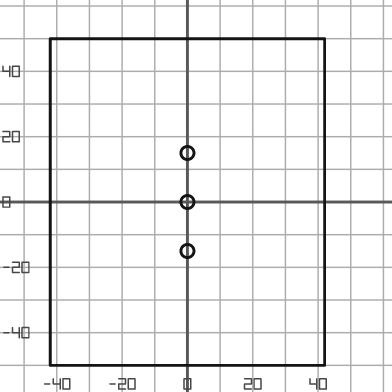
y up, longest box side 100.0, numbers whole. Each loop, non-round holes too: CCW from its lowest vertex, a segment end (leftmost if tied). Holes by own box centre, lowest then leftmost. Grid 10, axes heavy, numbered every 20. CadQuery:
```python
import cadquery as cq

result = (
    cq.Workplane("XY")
    .moveTo(-42.0, -50.0)
    .lineTo(42.0, -50.0)
    .lineTo(42.0, 50.0)
    .lineTo(-42.0, 50.0)
    .close()
    .moveTo(0.0, -15.0)
    .circle(2.0)
    .moveTo(0.0, 0.0)
    .circle(2.0)
    .moveTo(0.0, 15.0)
    .circle(2.0)
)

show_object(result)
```